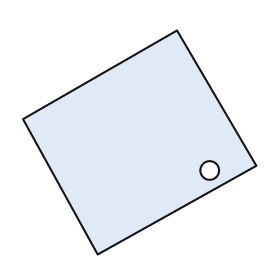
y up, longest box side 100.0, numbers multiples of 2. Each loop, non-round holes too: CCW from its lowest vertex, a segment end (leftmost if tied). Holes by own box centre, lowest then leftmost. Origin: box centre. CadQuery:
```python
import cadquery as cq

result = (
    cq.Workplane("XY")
    .moveTo(-18.0, -48.0)
    .lineTo(50.0, -10.0)
    .lineTo(16.0, 48.0)
    .lineTo(-50.0, 10.0)
    .close()
    .moveTo(30.0, -12.0)
    .circle(4.0)
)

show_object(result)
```